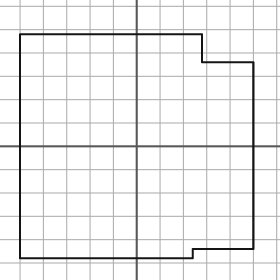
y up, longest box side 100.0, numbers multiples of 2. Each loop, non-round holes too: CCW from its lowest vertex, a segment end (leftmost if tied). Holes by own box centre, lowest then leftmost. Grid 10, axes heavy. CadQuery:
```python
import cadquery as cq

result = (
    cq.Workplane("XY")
    .moveTo(-50.0, -48.0)
    .lineTo(24.0, -48.0)
    .lineTo(24.0, -44.0)
    .lineTo(50.0, -44.0)
    .lineTo(50.0, 36.0)
    .lineTo(28.0, 36.0)
    .lineTo(28.0, 48.0)
    .lineTo(-50.0, 48.0)
    .close()
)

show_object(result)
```